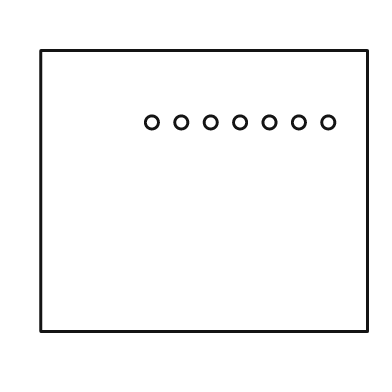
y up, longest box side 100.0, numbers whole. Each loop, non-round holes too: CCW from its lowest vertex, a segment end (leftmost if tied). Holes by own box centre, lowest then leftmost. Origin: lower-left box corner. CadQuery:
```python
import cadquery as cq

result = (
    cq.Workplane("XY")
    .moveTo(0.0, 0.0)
    .lineTo(100.0, 0.0)
    .lineTo(100.0, 86.0)
    .lineTo(0.0, 86.0)
    .close()
    .moveTo(34.0, 64.0)
    .circle(2.0)
    .moveTo(43.0, 64.0)
    .circle(2.0)
    .moveTo(52.0, 64.0)
    .circle(2.0)
    .moveTo(61.0, 64.0)
    .circle(2.0)
    .moveTo(70.0, 64.0)
    .circle(2.0)
    .moveTo(79.0, 64.0)
    .circle(2.0)
    .moveTo(88.0, 64.0)
    .circle(2.0)
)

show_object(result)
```